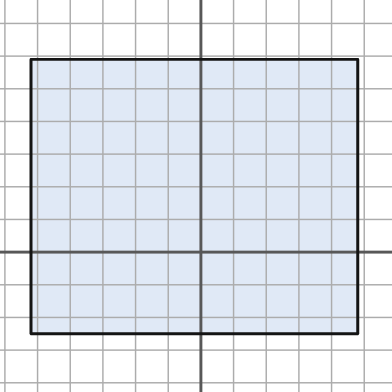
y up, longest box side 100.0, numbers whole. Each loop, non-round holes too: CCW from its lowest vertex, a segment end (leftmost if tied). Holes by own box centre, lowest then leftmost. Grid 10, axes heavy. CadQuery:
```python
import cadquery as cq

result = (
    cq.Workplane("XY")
    .moveTo(-52.0, -25.0)
    .lineTo(48.0, -25.0)
    .lineTo(48.0, 59.0)
    .lineTo(-52.0, 59.0)
    .close()
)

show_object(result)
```